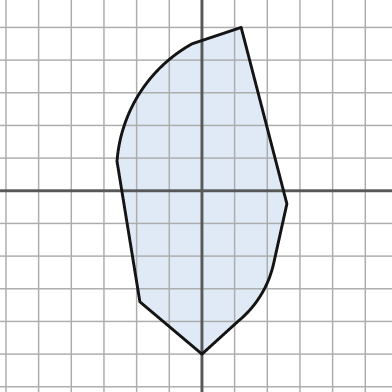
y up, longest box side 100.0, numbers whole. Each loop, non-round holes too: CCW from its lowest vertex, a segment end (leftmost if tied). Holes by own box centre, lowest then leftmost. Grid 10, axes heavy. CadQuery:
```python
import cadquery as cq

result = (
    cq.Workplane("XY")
    .moveTo(0.0, -50.0)
    .lineTo(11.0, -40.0)
    .threePointArc((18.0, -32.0), (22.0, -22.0))
    .lineTo(26.0, -4.0)
    .lineTo(12.0, 50.0)
    .lineTo(-3.0, 45.0)
    .threePointArc((-19.0, 30.0), (-26.0, 9.0))
    .lineTo(-19.0, -34.0)
    .close()
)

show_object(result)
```